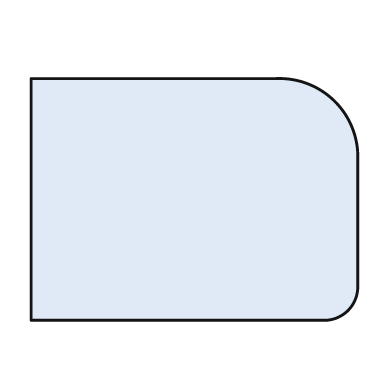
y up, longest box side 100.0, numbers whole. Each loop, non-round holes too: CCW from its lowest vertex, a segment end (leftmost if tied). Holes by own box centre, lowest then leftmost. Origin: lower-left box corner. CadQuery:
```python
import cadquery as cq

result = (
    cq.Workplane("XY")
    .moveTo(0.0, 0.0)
    .lineTo(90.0, 0.0)
    .threePointArc((97.0, 3.0), (100.0, 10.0))
    .lineTo(100.0, 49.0)
    .threePointArc((93.0, 67.0), (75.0, 74.0))
    .lineTo(0.0, 74.0)
    .close()
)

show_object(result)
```